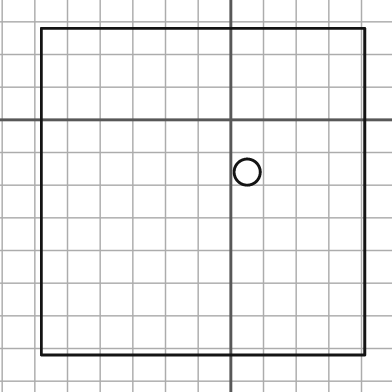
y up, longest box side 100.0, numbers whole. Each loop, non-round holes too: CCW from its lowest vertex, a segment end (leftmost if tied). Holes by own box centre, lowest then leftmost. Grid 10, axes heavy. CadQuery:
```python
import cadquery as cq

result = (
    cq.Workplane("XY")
    .moveTo(-58.0, -72.0)
    .lineTo(41.0, -72.0)
    .lineTo(41.0, 28.0)
    .lineTo(-58.0, 28.0)
    .close()
    .moveTo(5.0, -16.0)
    .circle(4.0)
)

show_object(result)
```